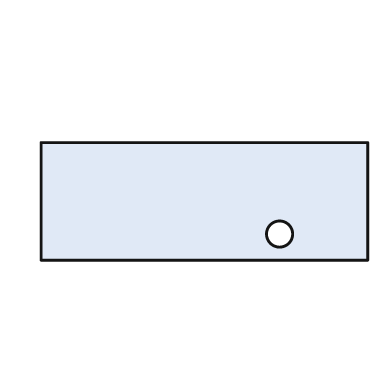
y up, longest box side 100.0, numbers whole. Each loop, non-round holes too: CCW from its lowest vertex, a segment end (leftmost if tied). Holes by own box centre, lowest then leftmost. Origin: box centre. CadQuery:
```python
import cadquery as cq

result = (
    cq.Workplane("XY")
    .moveTo(-50.0, -18.0)
    .lineTo(50.0, -18.0)
    .lineTo(50.0, 18.0)
    .lineTo(-50.0, 18.0)
    .close()
    .moveTo(23.0, -10.0)
    .circle(4.0)
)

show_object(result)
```